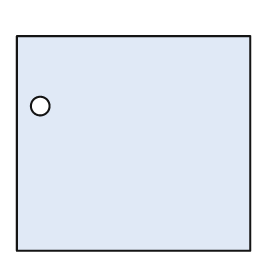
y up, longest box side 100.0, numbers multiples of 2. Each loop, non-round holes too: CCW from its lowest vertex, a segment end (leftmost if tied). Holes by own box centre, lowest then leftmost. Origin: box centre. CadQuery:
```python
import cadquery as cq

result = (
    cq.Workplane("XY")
    .moveTo(-50.0, -46.0)
    .lineTo(50.0, -46.0)
    .lineTo(50.0, 46.0)
    .lineTo(-50.0, 46.0)
    .close()
    .moveTo(-40.0, 16.0)
    .circle(4.0)
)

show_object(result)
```